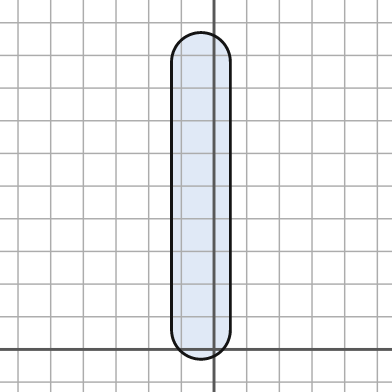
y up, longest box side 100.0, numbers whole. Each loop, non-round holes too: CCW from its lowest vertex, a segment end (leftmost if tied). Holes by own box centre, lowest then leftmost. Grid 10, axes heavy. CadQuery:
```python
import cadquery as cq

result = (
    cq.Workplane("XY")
    .moveTo(-13.0, 6.0)
    .threePointArc((-4.0, -3.0), (5.0, 6.0))
    .lineTo(5.0, 88.0)
    .threePointArc((-4.0, 97.0), (-13.0, 88.0))
    .close()
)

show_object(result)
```